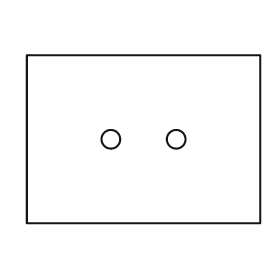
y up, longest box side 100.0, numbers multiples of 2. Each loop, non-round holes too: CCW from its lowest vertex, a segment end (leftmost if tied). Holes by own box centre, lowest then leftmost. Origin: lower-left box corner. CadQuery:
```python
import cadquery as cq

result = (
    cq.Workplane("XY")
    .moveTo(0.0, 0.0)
    .lineTo(100.0, 0.0)
    .lineTo(100.0, 72.0)
    .lineTo(0.0, 72.0)
    .close()
    .moveTo(36.0, 36.0)
    .circle(4.0)
    .moveTo(64.0, 36.0)
    .circle(4.0)
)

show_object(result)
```